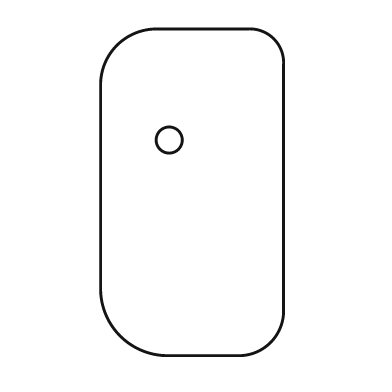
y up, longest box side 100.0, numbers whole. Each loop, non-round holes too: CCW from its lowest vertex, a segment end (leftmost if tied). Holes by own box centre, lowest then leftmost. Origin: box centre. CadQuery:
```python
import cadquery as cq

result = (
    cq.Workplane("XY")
    .moveTo(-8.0, -50.0)
    .lineTo(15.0, -50.0)
    .threePointArc((24.0, -46.0), (28.0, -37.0))
    .lineTo(28.0, 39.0)
    .threePointArc((25.0, 47.0), (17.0, 50.0))
    .lineTo(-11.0, 50.0)
    .threePointArc((-23.0, 45.0), (-28.0, 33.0))
    .lineTo(-28.0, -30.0)
    .threePointArc((-22.0, -44.0), (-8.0, -50.0))
    .close()
    .moveTo(-7.0, 16.0)
    .circle(4.0)
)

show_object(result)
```